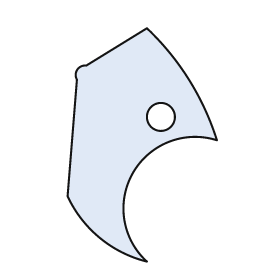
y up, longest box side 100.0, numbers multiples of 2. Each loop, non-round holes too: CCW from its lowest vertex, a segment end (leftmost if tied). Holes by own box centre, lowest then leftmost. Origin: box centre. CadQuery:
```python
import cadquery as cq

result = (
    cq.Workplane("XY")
    .moveTo(2.0, -50.0)
    .threePointArc((-4.0, -12.0), (32.0, 2.0))
    .threePointArc((20.0, 28.0), (2.0, 50.0))
    .lineTo(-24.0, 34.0)
    .threePointArc((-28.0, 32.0), (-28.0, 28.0))
    .lineTo(-32.0, -22.0)
    .threePointArc((-18.0, -40.0), (2.0, -50.0))
    .close()
    .moveTo(8.0, 12.0)
    .circle(6.0)
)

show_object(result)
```